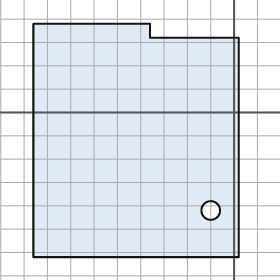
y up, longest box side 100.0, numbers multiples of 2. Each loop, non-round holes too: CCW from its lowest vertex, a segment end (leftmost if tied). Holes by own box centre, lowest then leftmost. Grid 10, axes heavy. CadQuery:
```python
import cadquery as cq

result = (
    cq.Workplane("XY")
    .moveTo(-86.0, -62.0)
    .lineTo(2.0, -62.0)
    .lineTo(2.0, 32.0)
    .lineTo(-36.0, 32.0)
    .lineTo(-36.0, 38.0)
    .lineTo(-86.0, 38.0)
    .close()
    .moveTo(-10.0, -42.0)
    .circle(4.0)
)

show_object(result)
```